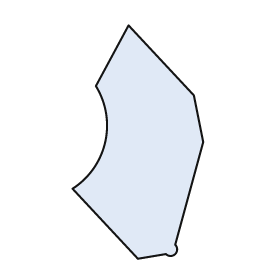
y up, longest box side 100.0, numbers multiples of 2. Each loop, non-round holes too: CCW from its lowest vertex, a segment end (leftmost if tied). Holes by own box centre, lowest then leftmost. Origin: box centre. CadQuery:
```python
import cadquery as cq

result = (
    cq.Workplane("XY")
    .moveTo(0.0, -50.0)
    .lineTo(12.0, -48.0)
    .threePointArc((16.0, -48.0), (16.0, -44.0))
    .lineTo(28.0, 0.0)
    .lineTo(24.0, 20.0)
    .lineTo(-4.0, 50.0)
    .lineTo(-18.0, 24.0)
    .threePointArc((-14.0, 0.0), (-28.0, -20.0))
    .close()
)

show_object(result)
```